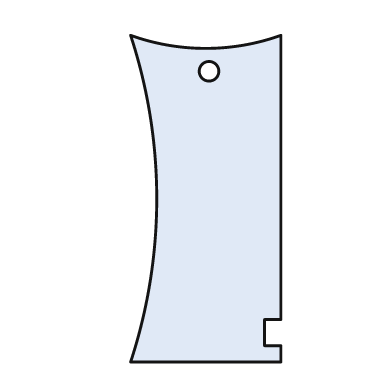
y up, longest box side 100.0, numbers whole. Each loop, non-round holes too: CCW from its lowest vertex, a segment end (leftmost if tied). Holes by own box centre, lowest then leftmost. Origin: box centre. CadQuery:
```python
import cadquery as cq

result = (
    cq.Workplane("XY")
    .moveTo(-23.0, -50.0)
    .lineTo(23.0, -50.0)
    .lineTo(23.0, -45.0)
    .lineTo(18.0, -45.0)
    .lineTo(18.0, -37.0)
    .lineTo(23.0, -37.0)
    .lineTo(23.0, 50.0)
    .threePointArc((0.0, 46.0), (-23.0, 50.0))
    .threePointArc((-15.0, 0.0), (-23.0, -50.0))
    .close()
    .moveTo(1.0, 39.0)
    .circle(3.0)
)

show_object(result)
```